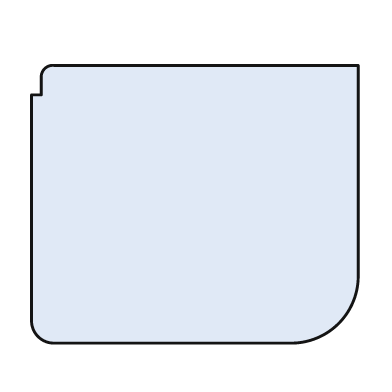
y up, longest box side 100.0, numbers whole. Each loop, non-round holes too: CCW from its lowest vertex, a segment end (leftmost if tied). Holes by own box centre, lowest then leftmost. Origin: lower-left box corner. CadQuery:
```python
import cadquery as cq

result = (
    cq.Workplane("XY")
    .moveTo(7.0, 0.0)
    .lineTo(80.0, 0.0)
    .threePointArc((94.0, 6.0), (100.0, 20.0))
    .lineTo(100.0, 85.0)
    .lineTo(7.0, 85.0)
    .threePointArc((4.0, 84.0), (3.0, 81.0))
    .lineTo(3.0, 76.0)
    .lineTo(0.0, 76.0)
    .lineTo(0.0, 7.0)
    .threePointArc((2.0, 2.0), (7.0, 0.0))
    .close()
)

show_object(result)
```